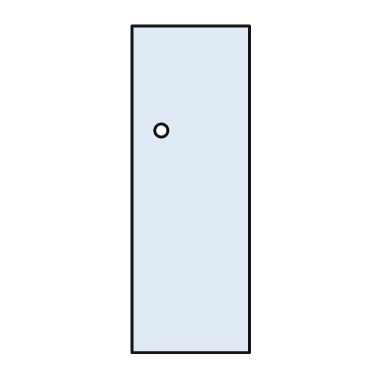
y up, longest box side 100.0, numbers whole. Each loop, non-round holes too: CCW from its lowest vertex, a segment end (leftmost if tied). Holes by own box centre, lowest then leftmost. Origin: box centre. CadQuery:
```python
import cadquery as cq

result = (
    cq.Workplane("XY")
    .moveTo(-18.0, -50.0)
    .lineTo(18.0, -50.0)
    .lineTo(18.0, 50.0)
    .lineTo(-18.0, 50.0)
    .close()
    .moveTo(-9.0, 18.0)
    .circle(2.0)
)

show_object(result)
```